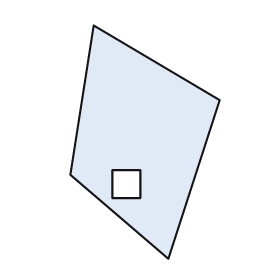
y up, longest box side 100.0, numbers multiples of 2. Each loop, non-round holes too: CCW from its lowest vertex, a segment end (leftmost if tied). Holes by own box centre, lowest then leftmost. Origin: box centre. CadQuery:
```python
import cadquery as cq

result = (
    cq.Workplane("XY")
    .moveTo(10.0, -50.0)
    .lineTo(32.0, 18.0)
    .lineTo(-22.0, 50.0)
    .lineTo(-32.0, -14.0)
    .close()
    .moveTo(-14.0, -24.0)
    .lineTo(-2.0, -24.0)
    .lineTo(-2.0, -12.0)
    .lineTo(-14.0, -12.0)
    .close()
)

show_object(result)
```